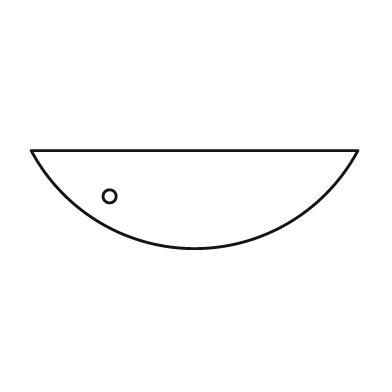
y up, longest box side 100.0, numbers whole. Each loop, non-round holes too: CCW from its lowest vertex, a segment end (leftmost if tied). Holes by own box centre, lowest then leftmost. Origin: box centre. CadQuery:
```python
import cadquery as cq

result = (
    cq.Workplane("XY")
    .moveTo(-50.0, 15.0)
    .threePointArc((0.0, -15.0), (50.0, 15.0))
    .close()
    .moveTo(-26.0, 1.0)
    .circle(2.0)
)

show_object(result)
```